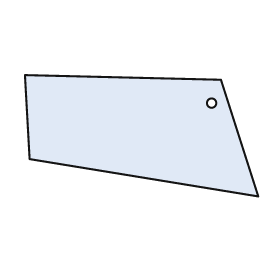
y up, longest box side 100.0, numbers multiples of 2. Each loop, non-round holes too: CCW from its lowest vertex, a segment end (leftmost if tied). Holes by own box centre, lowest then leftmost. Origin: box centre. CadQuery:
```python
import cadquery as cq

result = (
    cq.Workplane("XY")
    .moveTo(50.0, -26.0)
    .lineTo(34.0, 24.0)
    .lineTo(-50.0, 26.0)
    .lineTo(-48.0, -10.0)
    .close()
    .moveTo(30.0, 14.0)
    .circle(2.0)
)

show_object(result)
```